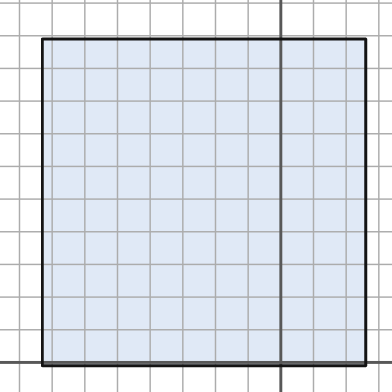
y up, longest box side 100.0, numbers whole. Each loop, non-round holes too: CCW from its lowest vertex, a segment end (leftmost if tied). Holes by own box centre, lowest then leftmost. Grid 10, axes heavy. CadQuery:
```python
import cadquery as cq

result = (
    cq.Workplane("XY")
    .moveTo(-73.0, -1.0)
    .lineTo(26.0, -1.0)
    .lineTo(26.0, 99.0)
    .lineTo(-73.0, 99.0)
    .close()
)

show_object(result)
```